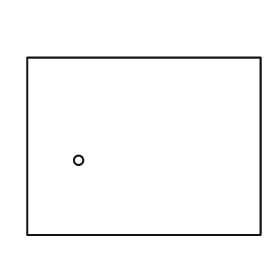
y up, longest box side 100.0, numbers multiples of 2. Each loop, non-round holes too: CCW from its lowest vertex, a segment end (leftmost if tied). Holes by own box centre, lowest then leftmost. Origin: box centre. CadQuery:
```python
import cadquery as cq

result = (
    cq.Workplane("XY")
    .moveTo(-50.0, -38.0)
    .lineTo(50.0, -38.0)
    .lineTo(50.0, 38.0)
    .lineTo(-50.0, 38.0)
    .close()
    .moveTo(-28.0, -6.0)
    .circle(2.0)
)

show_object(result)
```